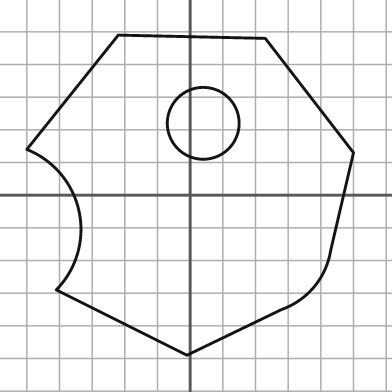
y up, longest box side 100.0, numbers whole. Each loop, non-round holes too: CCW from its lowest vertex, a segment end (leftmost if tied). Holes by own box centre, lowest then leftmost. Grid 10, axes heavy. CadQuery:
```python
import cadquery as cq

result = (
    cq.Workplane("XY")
    .moveTo(-1.0, -49.0)
    .lineTo(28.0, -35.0)
    .threePointArc((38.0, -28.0), (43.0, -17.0))
    .lineTo(50.0, 13.0)
    .lineTo(23.0, 48.0)
    .lineTo(-22.0, 49.0)
    .lineTo(-50.0, 14.0)
    .threePointArc((-34.0, -5.0), (-41.0, -29.0))
    .close()
    .moveTo(4.0, 22.0)
    .circle(11.0)
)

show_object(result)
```